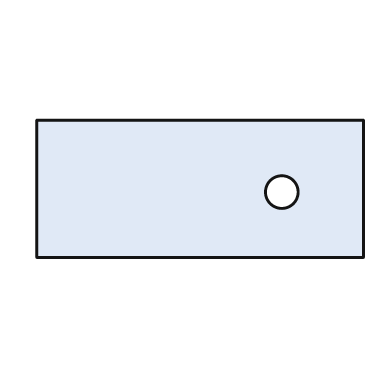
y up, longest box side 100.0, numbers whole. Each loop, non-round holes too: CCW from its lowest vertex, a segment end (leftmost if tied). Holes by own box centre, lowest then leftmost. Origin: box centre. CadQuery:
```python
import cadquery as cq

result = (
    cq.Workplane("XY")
    .moveTo(-50.0, -21.0)
    .lineTo(50.0, -21.0)
    .lineTo(50.0, 21.0)
    .lineTo(-50.0, 21.0)
    .close()
    .moveTo(25.0, -1.0)
    .circle(5.0)
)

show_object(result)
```